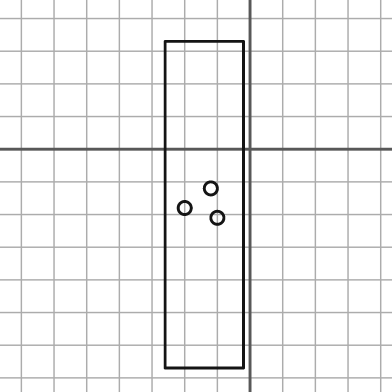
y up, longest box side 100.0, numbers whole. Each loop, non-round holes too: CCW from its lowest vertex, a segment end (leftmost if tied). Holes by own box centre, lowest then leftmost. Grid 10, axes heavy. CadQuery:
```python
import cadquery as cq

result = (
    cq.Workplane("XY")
    .moveTo(-26.0, -67.0)
    .lineTo(-2.0, -67.0)
    .lineTo(-2.0, 33.0)
    .lineTo(-26.0, 33.0)
    .close()
    .moveTo(-10.0, -21.0)
    .circle(2.0)
    .moveTo(-20.0, -18.0)
    .circle(2.0)
    .moveTo(-12.0, -12.0)
    .circle(2.0)
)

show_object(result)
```